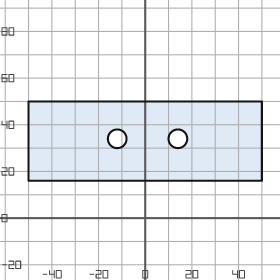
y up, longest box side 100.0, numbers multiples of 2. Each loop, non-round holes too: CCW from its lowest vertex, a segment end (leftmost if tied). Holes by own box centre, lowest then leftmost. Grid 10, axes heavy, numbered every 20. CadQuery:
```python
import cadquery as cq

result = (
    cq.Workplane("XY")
    .moveTo(-50.0, 16.0)
    .lineTo(50.0, 16.0)
    .lineTo(50.0, 50.0)
    .lineTo(-50.0, 50.0)
    .close()
    .moveTo(-12.0, 34.0)
    .circle(4.0)
    .moveTo(14.0, 34.0)
    .circle(4.0)
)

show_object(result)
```